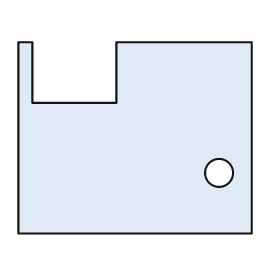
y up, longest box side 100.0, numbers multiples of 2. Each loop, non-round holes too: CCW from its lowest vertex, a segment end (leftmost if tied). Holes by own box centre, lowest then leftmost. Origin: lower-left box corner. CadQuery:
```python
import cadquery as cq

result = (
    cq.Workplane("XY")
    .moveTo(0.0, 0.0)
    .lineTo(100.0, 0.0)
    .lineTo(100.0, 82.0)
    .lineTo(42.0, 82.0)
    .lineTo(42.0, 56.0)
    .lineTo(6.0, 56.0)
    .lineTo(6.0, 82.0)
    .lineTo(0.0, 82.0)
    .close()
    .moveTo(86.0, 26.0)
    .circle(6.0)
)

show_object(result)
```